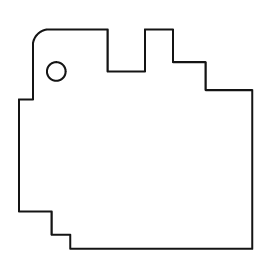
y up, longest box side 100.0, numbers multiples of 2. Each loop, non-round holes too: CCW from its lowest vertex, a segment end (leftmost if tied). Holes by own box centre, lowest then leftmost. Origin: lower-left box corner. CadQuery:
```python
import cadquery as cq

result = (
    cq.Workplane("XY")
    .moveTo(22.0, 0.0)
    .lineTo(100.0, 0.0)
    .lineTo(100.0, 68.0)
    .lineTo(80.0, 68.0)
    .lineTo(80.0, 80.0)
    .lineTo(66.0, 80.0)
    .lineTo(66.0, 94.0)
    .lineTo(54.0, 94.0)
    .lineTo(54.0, 76.0)
    .lineTo(38.0, 76.0)
    .lineTo(38.0, 94.0)
    .lineTo(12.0, 94.0)
    .threePointArc((8.0, 92.0), (6.0, 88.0))
    .lineTo(6.0, 64.0)
    .lineTo(0.0, 64.0)
    .lineTo(0.0, 16.0)
    .lineTo(14.0, 16.0)
    .lineTo(14.0, 6.0)
    .lineTo(22.0, 6.0)
    .close()
    .moveTo(16.0, 76.0)
    .circle(4.0)
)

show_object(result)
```